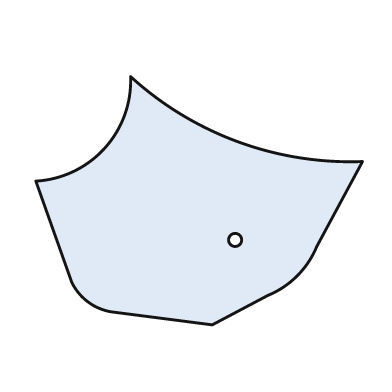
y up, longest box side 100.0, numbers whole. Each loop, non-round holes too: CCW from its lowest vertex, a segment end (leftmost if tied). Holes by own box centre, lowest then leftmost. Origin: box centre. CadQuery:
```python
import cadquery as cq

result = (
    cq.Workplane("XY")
    .moveTo(4.0, -38.0)
    .lineTo(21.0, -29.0)
    .threePointArc((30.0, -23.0), (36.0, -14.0))
    .lineTo(50.0, 12.0)
    .threePointArc((12.0, 18.0), (-21.0, 38.0))
    .threePointArc((-29.0, 16.0), (-50.0, 6.0))
    .lineTo(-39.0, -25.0)
    .threePointArc((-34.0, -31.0), (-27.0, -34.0))
    .close()
    .moveTo(11.0, -12.0)
    .circle(2.0)
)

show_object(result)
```